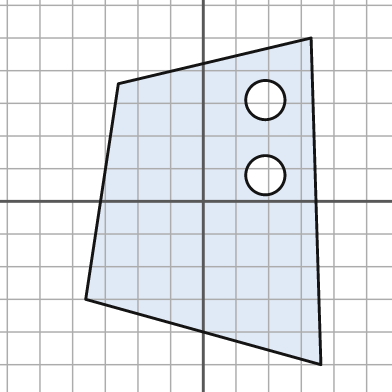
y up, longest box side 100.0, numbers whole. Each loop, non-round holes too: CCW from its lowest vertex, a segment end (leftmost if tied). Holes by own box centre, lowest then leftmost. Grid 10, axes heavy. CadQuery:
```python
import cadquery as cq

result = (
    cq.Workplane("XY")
    .moveTo(36.0, -50.0)
    .lineTo(33.0, 50.0)
    .lineTo(-26.0, 36.0)
    .lineTo(-36.0, -30.0)
    .close()
    .moveTo(19.0, 8.0)
    .circle(6.0)
    .moveTo(19.0, 31.0)
    .circle(6.0)
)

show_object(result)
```